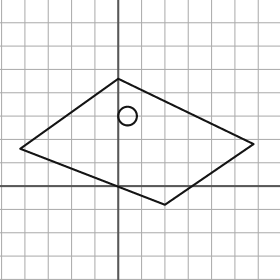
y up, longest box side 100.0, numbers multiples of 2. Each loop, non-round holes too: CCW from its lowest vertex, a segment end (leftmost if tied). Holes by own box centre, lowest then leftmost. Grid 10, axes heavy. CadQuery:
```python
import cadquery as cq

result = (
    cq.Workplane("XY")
    .moveTo(20.0, -8.0)
    .lineTo(58.0, 18.0)
    .lineTo(0.0, 46.0)
    .lineTo(-42.0, 16.0)
    .close()
    .moveTo(4.0, 30.0)
    .circle(4.0)
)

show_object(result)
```